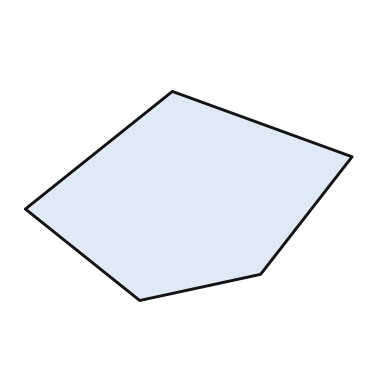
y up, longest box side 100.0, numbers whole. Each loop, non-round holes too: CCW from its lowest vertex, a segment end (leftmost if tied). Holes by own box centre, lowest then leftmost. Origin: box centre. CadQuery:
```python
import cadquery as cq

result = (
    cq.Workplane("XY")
    .moveTo(-15.0, -32.0)
    .lineTo(22.0, -24.0)
    .lineTo(50.0, 12.0)
    .lineTo(-5.0, 32.0)
    .lineTo(-50.0, -4.0)
    .close()
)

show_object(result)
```